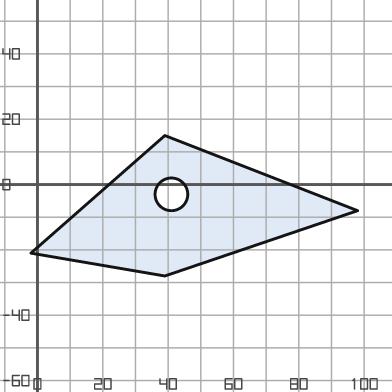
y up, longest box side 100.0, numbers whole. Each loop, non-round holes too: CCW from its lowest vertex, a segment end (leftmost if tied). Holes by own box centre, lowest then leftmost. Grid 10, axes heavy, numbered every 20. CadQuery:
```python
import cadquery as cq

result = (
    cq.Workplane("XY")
    .moveTo(39.0, -28.0)
    .lineTo(98.0, -8.0)
    .lineTo(39.0, 15.0)
    .lineTo(-2.0, -21.0)
    .close()
    .moveTo(41.0, -3.0)
    .circle(5.0)
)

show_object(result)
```